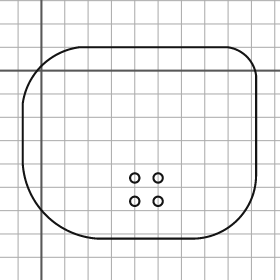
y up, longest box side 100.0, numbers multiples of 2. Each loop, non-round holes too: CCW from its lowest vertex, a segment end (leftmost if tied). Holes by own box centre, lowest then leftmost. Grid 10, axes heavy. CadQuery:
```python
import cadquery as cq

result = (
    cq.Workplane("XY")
    .moveTo(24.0, -72.0)
    .lineTo(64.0, -72.0)
    .threePointArc((84.0, -64.0), (92.0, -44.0))
    .lineTo(92.0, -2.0)
    .threePointArc((88.0, 6.0), (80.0, 10.0))
    .lineTo(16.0, 10.0)
    .threePointArc((0.0, 2.0), (-8.0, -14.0))
    .lineTo(-8.0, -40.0)
    .threePointArc((2.0, -62.0), (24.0, -72.0))
    .close()
    .moveTo(40.0, -56.0)
    .circle(2.0)
    .moveTo(50.0, -56.0)
    .circle(2.0)
    .moveTo(40.0, -46.0)
    .circle(2.0)
    .moveTo(50.0, -46.0)
    .circle(2.0)
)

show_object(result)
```